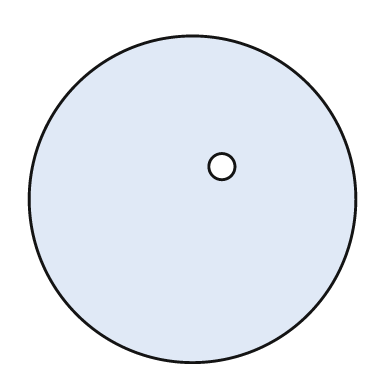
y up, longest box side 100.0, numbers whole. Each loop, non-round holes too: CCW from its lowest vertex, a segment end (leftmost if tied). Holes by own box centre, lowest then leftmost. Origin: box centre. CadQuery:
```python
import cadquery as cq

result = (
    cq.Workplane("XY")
    .moveTo(0.0, 0.0)
    .circle(50.0)
    .moveTo(9.0, 10.0)
    .circle(4.0)
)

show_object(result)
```